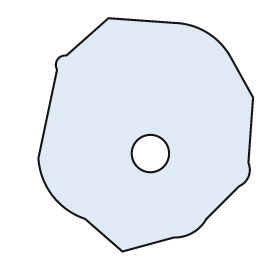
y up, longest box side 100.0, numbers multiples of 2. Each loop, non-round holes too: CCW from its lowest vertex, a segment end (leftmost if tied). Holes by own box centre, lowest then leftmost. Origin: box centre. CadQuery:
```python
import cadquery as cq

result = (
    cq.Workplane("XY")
    .moveTo(-10.0, -50.0)
    .lineTo(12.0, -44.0)
    .threePointArc((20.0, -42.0), (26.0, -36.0))
    .lineTo(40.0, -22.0)
    .threePointArc((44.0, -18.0), (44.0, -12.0))
    .lineTo(46.0, 16.0)
    .lineTo(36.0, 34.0)
    .threePointArc((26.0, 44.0), (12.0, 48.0))
    .lineTo(-16.0, 50.0)
    .lineTo(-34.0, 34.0)
    .threePointArc((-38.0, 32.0), (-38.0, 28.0))
    .lineTo(-46.0, -10.0)
    .threePointArc((-40.0, -26.0), (-26.0, -36.0))
    .close()
    .moveTo(2.0, -8.0)
    .circle(8.0)
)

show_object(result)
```